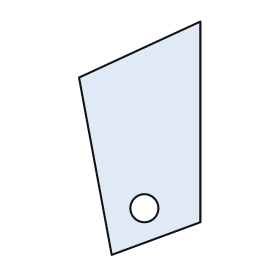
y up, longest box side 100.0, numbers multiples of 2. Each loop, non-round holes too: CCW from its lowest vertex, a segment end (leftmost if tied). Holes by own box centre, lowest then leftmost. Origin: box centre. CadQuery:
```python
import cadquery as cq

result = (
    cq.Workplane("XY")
    .moveTo(-12.0, -50.0)
    .lineTo(26.0, -36.0)
    .lineTo(26.0, 50.0)
    .lineTo(-26.0, 26.0)
    .close()
    .moveTo(2.0, -30.0)
    .circle(6.0)
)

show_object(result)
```